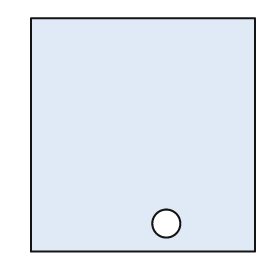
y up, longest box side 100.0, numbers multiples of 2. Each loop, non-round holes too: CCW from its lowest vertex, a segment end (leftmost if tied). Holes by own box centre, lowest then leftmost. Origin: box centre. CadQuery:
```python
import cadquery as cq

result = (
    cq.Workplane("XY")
    .moveTo(-48.0, -50.0)
    .lineTo(48.0, -50.0)
    .lineTo(48.0, 50.0)
    .lineTo(-48.0, 50.0)
    .close()
    .moveTo(10.0, -38.0)
    .circle(6.0)
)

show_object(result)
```